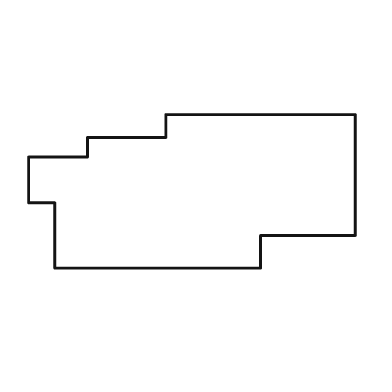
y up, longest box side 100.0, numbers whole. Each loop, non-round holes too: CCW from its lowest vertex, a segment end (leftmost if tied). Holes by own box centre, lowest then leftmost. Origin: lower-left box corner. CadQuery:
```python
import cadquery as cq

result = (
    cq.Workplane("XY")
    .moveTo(8.0, 0.0)
    .lineTo(71.0, 0.0)
    .lineTo(71.0, 10.0)
    .lineTo(100.0, 10.0)
    .lineTo(100.0, 47.0)
    .lineTo(42.0, 47.0)
    .lineTo(42.0, 40.0)
    .lineTo(18.0, 40.0)
    .lineTo(18.0, 34.0)
    .lineTo(0.0, 34.0)
    .lineTo(0.0, 20.0)
    .lineTo(8.0, 20.0)
    .close()
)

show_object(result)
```